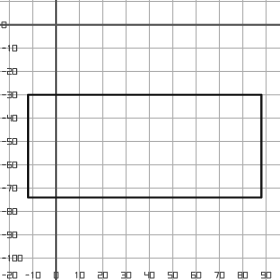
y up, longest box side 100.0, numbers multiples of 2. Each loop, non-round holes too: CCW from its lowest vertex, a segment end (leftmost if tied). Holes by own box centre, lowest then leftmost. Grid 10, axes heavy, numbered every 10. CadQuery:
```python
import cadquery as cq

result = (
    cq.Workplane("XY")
    .moveTo(-12.0, -74.0)
    .lineTo(88.0, -74.0)
    .lineTo(88.0, -30.0)
    .lineTo(-12.0, -30.0)
    .close()
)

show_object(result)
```